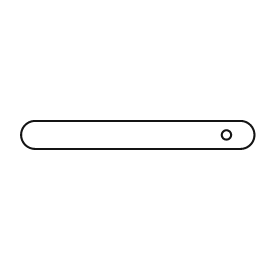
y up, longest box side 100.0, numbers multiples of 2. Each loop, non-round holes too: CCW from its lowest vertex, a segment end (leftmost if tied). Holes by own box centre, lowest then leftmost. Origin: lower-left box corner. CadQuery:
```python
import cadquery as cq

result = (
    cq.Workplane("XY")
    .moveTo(6.0, 0.0)
    .lineTo(94.0, 0.0)
    .threePointArc((100.0, 6.0), (94.0, 12.0))
    .lineTo(6.0, 12.0)
    .threePointArc((0.0, 6.0), (6.0, 0.0))
    .close()
    .moveTo(88.0, 6.0)
    .circle(2.0)
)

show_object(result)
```